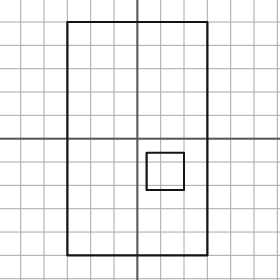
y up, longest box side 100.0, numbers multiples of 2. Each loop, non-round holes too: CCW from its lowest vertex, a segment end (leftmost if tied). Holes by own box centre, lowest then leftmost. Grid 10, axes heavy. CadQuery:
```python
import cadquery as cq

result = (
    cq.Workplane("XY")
    .moveTo(-30.0, -50.0)
    .lineTo(30.0, -50.0)
    .lineTo(30.0, 50.0)
    .lineTo(-30.0, 50.0)
    .close()
    .moveTo(4.0, -22.0)
    .lineTo(20.0, -22.0)
    .lineTo(20.0, -6.0)
    .lineTo(4.0, -6.0)
    .close()
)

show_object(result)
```